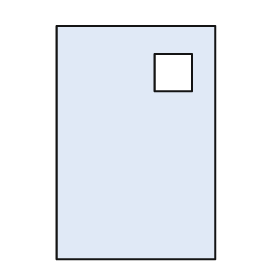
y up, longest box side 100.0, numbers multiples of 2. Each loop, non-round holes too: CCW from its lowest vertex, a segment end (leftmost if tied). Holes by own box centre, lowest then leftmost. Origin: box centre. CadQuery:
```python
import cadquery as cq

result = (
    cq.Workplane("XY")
    .moveTo(-34.0, -50.0)
    .lineTo(34.0, -50.0)
    .lineTo(34.0, 50.0)
    .lineTo(-34.0, 50.0)
    .close()
    .moveTo(8.0, 22.0)
    .lineTo(24.0, 22.0)
    .lineTo(24.0, 38.0)
    .lineTo(8.0, 38.0)
    .close()
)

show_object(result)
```